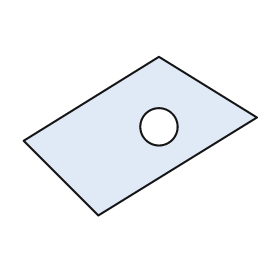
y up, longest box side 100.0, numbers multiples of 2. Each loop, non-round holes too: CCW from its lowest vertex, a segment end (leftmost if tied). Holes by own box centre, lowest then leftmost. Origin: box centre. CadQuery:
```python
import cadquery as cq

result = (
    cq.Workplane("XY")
    .moveTo(-18.0, -34.0)
    .lineTo(50.0, 8.0)
    .lineTo(8.0, 34.0)
    .lineTo(-50.0, -2.0)
    .close()
    .moveTo(8.0, 4.0)
    .circle(8.0)
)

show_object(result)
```